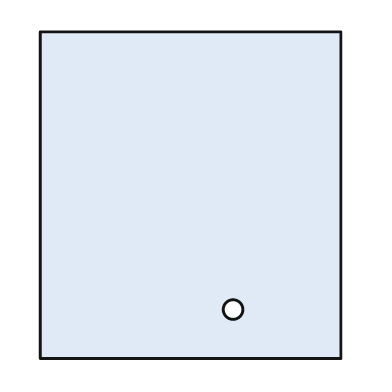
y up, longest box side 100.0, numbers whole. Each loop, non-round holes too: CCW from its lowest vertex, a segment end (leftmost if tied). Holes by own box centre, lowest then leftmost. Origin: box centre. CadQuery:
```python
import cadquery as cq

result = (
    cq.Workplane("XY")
    .moveTo(-46.0, -50.0)
    .lineTo(46.0, -50.0)
    .lineTo(46.0, 50.0)
    .lineTo(-46.0, 50.0)
    .close()
    .moveTo(13.0, -35.0)
    .circle(3.0)
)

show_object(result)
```